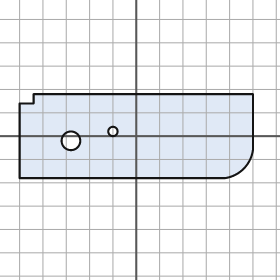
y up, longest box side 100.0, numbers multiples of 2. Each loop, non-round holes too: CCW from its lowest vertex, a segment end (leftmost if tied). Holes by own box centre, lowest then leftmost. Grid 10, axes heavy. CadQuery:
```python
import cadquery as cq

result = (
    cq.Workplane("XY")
    .moveTo(-50.0, -18.0)
    .lineTo(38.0, -18.0)
    .threePointArc((46.0, -14.0), (50.0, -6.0))
    .lineTo(50.0, 18.0)
    .lineTo(-44.0, 18.0)
    .lineTo(-44.0, 14.0)
    .lineTo(-50.0, 14.0)
    .close()
    .moveTo(-28.0, -2.0)
    .circle(4.0)
    .moveTo(-10.0, 2.0)
    .circle(2.0)
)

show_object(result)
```